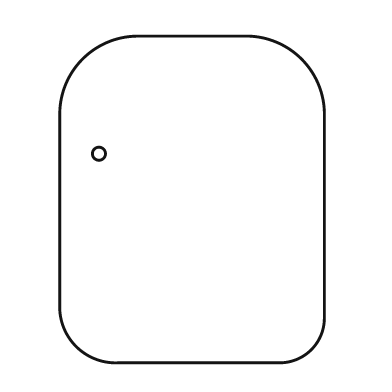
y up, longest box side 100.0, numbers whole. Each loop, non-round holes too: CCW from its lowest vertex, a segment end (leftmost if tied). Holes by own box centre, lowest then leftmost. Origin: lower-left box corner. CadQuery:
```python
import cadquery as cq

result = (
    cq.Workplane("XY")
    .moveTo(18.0, 0.0)
    .lineTo(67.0, 0.0)
    .threePointArc((77.0, 4.0), (81.0, 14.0))
    .lineTo(81.0, 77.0)
    .threePointArc((74.0, 93.0), (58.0, 100.0))
    .lineTo(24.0, 100.0)
    .threePointArc((7.0, 93.0), (0.0, 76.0))
    .lineTo(0.0, 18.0)
    .threePointArc((5.0, 5.0), (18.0, 0.0))
    .close()
    .moveTo(12.0, 64.0)
    .circle(2.0)
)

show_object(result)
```